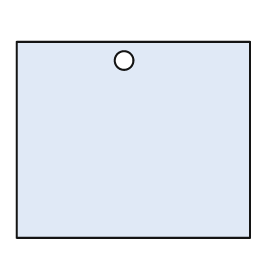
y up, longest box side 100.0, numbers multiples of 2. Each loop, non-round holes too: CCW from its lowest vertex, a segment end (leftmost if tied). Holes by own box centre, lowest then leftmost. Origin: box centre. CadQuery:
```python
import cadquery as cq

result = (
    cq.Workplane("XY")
    .moveTo(-50.0, -42.0)
    .lineTo(50.0, -42.0)
    .lineTo(50.0, 42.0)
    .lineTo(-50.0, 42.0)
    .close()
    .moveTo(-4.0, 34.0)
    .circle(4.0)
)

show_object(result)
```